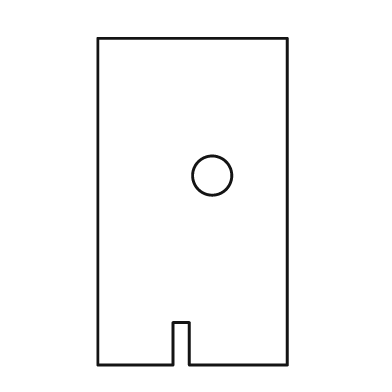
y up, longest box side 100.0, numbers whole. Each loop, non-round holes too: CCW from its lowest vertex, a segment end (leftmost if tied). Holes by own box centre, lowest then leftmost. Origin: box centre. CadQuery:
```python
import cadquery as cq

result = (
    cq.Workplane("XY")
    .moveTo(-29.0, -50.0)
    .lineTo(-6.0, -50.0)
    .lineTo(-6.0, -37.0)
    .lineTo(-1.0, -37.0)
    .lineTo(-1.0, -50.0)
    .lineTo(29.0, -50.0)
    .lineTo(29.0, 50.0)
    .lineTo(-29.0, 50.0)
    .close()
    .moveTo(6.0, 8.0)
    .circle(6.0)
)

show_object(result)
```